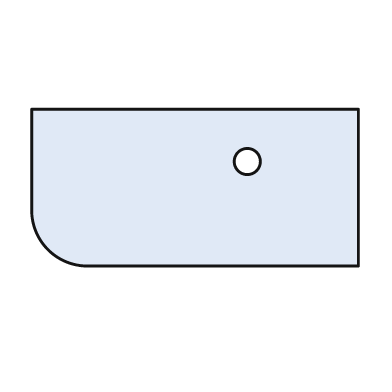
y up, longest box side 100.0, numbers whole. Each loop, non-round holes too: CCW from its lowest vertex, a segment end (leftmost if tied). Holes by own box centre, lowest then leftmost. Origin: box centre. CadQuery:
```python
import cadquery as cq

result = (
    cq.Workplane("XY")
    .moveTo(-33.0, -24.0)
    .lineTo(50.0, -24.0)
    .lineTo(50.0, 24.0)
    .lineTo(-50.0, 24.0)
    .lineTo(-50.0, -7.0)
    .threePointArc((-45.0, -19.0), (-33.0, -24.0))
    .close()
    .moveTo(16.0, 8.0)
    .circle(4.0)
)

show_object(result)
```